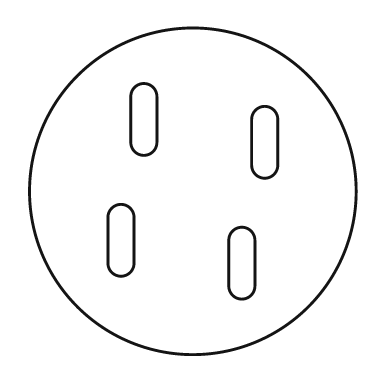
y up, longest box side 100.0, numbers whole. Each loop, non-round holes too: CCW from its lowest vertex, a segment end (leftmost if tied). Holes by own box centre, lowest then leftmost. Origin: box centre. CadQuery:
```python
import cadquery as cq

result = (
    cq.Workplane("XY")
    .moveTo(0.0, 0.0)
    .circle(50.0)
    .moveTo(11.0, -29.0)
    .threePointArc((15.0, -33.0), (19.0, -29.0))
    .lineTo(19.0, -15.0)
    .threePointArc((15.0, -11.0), (11.0, -15.0))
    .close()
    .moveTo(-26.0, -22.0)
    .threePointArc((-22.0, -26.0), (-18.0, -22.0))
    .lineTo(-18.0, -8.0)
    .threePointArc((-22.0, -4.0), (-26.0, -8.0))
    .close()
    .moveTo(18.0, 8.0)
    .threePointArc((22.0, 4.0), (26.0, 8.0))
    .lineTo(26.0, 22.0)
    .threePointArc((22.0, 26.0), (18.0, 22.0))
    .close()
    .moveTo(-19.0, 15.0)
    .threePointArc((-15.0, 11.0), (-11.0, 15.0))
    .lineTo(-11.0, 29.0)
    .threePointArc((-15.0, 33.0), (-19.0, 29.0))
    .close()
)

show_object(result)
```